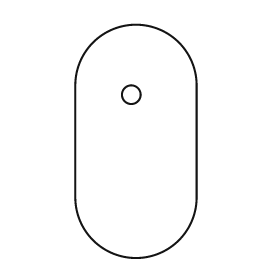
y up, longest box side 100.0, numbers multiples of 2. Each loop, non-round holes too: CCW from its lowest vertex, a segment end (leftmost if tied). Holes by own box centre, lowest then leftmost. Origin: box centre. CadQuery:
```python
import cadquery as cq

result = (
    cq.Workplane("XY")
    .moveTo(-26.0, -24.0)
    .threePointArc((0.0, -50.0), (26.0, -24.0))
    .lineTo(26.0, 24.0)
    .threePointArc((0.0, 50.0), (-26.0, 24.0))
    .close()
    .moveTo(-2.0, 20.0)
    .circle(4.0)
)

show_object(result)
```